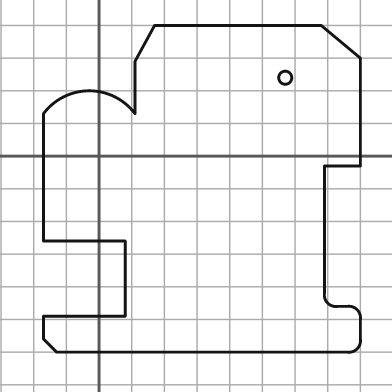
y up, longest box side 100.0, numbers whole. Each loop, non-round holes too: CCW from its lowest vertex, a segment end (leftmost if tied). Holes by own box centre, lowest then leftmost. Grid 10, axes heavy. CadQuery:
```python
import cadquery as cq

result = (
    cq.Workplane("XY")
    .moveTo(-13.0, -60.0)
    .lineTo(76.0, -60.0)
    .threePointArc((79.0, -59.0), (80.0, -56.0))
    .lineTo(80.0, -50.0)
    .threePointArc((79.0, -47.0), (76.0, -46.0))
    .lineTo(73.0, -46.0)
    .threePointArc((70.0, -45.0), (69.0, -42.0))
    .lineTo(69.0, -3.0)
    .lineTo(80.0, -3.0)
    .lineTo(80.0, 30.0)
    .lineTo(68.0, 40.0)
    .lineTo(17.0, 40.0)
    .lineTo(11.0, 29.0)
    .lineTo(11.0, 13.0)
    .threePointArc((-3.0, 20.0), (-17.0, 13.0))
    .lineTo(-17.0, -26.0)
    .lineTo(8.0, -26.0)
    .lineTo(8.0, -49.0)
    .lineTo(-17.0, -49.0)
    .lineTo(-17.0, -56.0)
    .close()
    .moveTo(57.0, 24.0)
    .circle(2.0)
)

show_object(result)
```